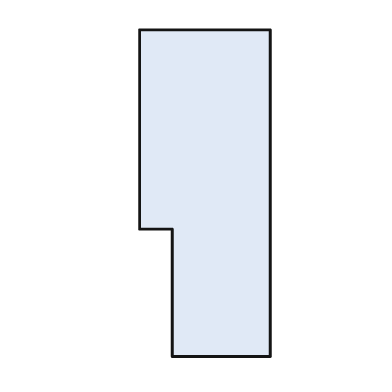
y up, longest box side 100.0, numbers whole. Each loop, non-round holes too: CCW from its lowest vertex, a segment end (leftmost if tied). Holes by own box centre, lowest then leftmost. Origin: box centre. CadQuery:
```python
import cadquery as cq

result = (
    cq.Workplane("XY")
    .moveTo(-10.0, -50.0)
    .lineTo(20.0, -50.0)
    .lineTo(20.0, 50.0)
    .lineTo(-20.0, 50.0)
    .lineTo(-20.0, -11.0)
    .lineTo(-10.0, -11.0)
    .close()
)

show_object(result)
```